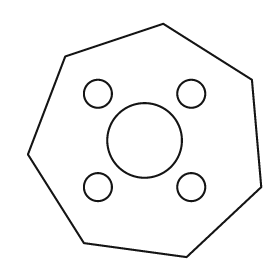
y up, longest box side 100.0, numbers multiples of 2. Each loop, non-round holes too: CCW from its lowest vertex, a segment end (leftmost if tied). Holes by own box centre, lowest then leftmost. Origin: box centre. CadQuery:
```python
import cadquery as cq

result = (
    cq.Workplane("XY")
    .moveTo(18.0, -50.0)
    .lineTo(50.0, -20.0)
    .lineTo(46.0, 26.0)
    .lineTo(8.0, 50.0)
    .lineTo(-34.0, 36.0)
    .lineTo(-50.0, -6.0)
    .lineTo(-26.0, -44.0)
    .close()
    .moveTo(-20.0, -20.0)
    .circle(6.0)
    .moveTo(20.0, -20.0)
    .circle(6.0)
    .moveTo(0.0, 0.0)
    .circle(16.0)
    .moveTo(-20.0, 20.0)
    .circle(6.0)
    .moveTo(20.0, 20.0)
    .circle(6.0)
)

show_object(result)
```